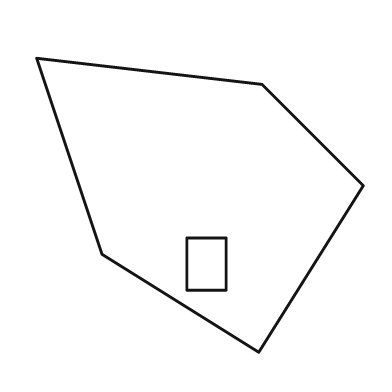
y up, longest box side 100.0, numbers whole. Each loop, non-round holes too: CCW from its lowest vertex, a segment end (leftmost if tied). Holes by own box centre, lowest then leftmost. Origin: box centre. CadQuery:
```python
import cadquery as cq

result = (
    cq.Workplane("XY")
    .moveTo(18.0, -45.0)
    .lineTo(50.0, 6.0)
    .lineTo(19.0, 37.0)
    .lineTo(-50.0, 45.0)
    .lineTo(-30.0, -15.0)
    .close()
    .moveTo(-4.0, -26.0)
    .lineTo(8.0, -26.0)
    .lineTo(8.0, -10.0)
    .lineTo(-4.0, -10.0)
    .close()
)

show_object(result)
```